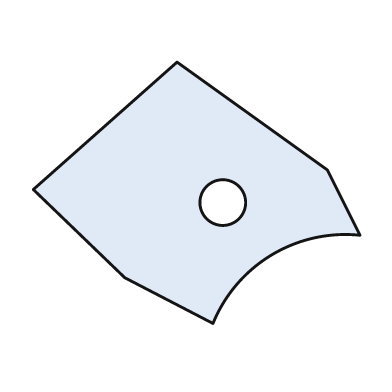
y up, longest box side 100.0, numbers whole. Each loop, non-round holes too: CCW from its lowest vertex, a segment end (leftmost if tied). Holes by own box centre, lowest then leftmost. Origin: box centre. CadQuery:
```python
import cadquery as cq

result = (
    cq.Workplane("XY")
    .moveTo(5.0, -40.0)
    .threePointArc((23.0, -19.0), (50.0, -13.0))
    .lineTo(40.0, 7.0)
    .lineTo(-6.0, 40.0)
    .lineTo(-50.0, 1.0)
    .lineTo(-22.0, -26.0)
    .close()
    .moveTo(8.0, -3.0)
    .circle(7.0)
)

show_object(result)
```